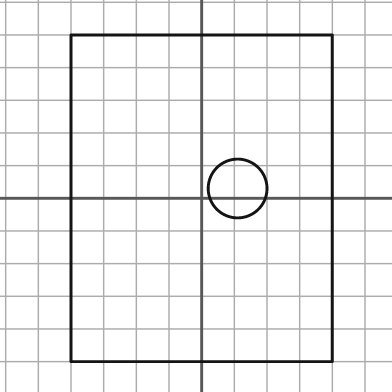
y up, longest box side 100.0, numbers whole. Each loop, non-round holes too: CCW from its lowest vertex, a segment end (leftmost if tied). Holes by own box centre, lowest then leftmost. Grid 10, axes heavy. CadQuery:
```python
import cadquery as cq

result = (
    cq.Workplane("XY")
    .moveTo(-40.0, -50.0)
    .lineTo(40.0, -50.0)
    .lineTo(40.0, 50.0)
    .lineTo(-40.0, 50.0)
    .close()
    .moveTo(11.0, 3.0)
    .circle(9.0)
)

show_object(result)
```